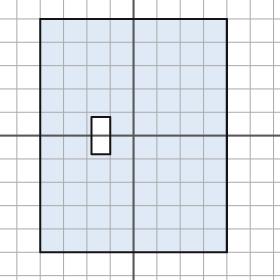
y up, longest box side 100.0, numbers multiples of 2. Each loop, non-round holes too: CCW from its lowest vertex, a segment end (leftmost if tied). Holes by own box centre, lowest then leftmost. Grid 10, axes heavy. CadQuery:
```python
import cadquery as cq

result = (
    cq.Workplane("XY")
    .moveTo(-40.0, -50.0)
    .lineTo(40.0, -50.0)
    .lineTo(40.0, 50.0)
    .lineTo(-40.0, 50.0)
    .close()
    .moveTo(-18.0, -8.0)
    .lineTo(-10.0, -8.0)
    .lineTo(-10.0, 8.0)
    .lineTo(-18.0, 8.0)
    .close()
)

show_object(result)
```